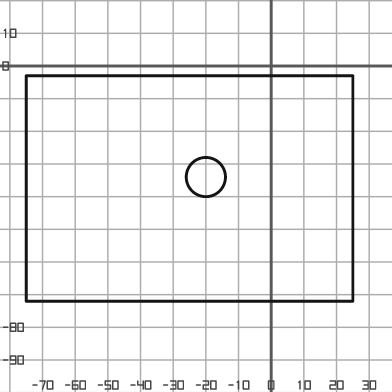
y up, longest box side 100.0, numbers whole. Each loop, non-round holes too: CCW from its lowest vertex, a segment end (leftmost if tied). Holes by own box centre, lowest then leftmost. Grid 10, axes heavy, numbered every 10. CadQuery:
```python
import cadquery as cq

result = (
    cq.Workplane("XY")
    .moveTo(-75.0, -72.0)
    .lineTo(25.0, -72.0)
    .lineTo(25.0, -3.0)
    .lineTo(-75.0, -3.0)
    .close()
    .moveTo(-20.0, -34.0)
    .circle(6.0)
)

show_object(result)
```